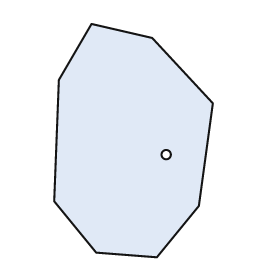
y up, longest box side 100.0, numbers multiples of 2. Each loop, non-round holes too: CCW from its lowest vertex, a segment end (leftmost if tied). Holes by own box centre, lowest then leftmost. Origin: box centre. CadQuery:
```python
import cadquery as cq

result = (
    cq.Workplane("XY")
    .moveTo(10.0, -50.0)
    .lineTo(28.0, -28.0)
    .lineTo(34.0, 16.0)
    .lineTo(8.0, 44.0)
    .lineTo(-18.0, 50.0)
    .lineTo(-32.0, 26.0)
    .lineTo(-34.0, -26.0)
    .lineTo(-16.0, -48.0)
    .close()
    .moveTo(14.0, -6.0)
    .circle(2.0)
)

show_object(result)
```